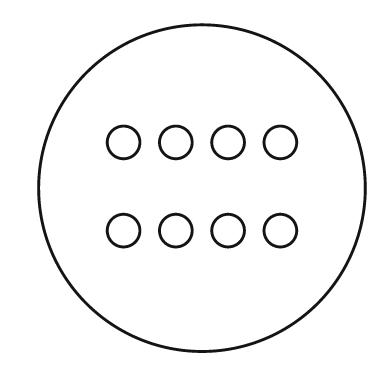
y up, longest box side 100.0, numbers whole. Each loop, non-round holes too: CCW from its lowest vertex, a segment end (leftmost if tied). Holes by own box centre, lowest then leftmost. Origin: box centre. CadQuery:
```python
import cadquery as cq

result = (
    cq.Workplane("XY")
    .moveTo(0.0, 0.0)
    .circle(50.0)
    .moveTo(-24.0, -13.0)
    .circle(5.0)
    .moveTo(-8.0, -13.0)
    .circle(5.0)
    .moveTo(8.0, -13.0)
    .circle(5.0)
    .moveTo(24.0, -13.0)
    .circle(5.0)
    .moveTo(-24.0, 14.0)
    .circle(5.0)
    .moveTo(-8.0, 14.0)
    .circle(5.0)
    .moveTo(8.0, 14.0)
    .circle(5.0)
    .moveTo(24.0, 14.0)
    .circle(5.0)
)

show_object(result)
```